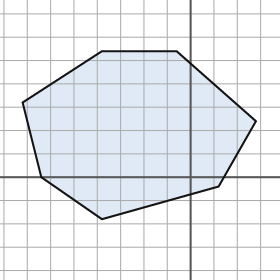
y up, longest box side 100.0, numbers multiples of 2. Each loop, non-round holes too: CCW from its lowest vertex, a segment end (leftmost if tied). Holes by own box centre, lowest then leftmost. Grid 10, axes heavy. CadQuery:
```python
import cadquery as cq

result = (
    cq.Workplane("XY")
    .moveTo(-38.0, -18.0)
    .lineTo(12.0, -4.0)
    .lineTo(28.0, 24.0)
    .lineTo(-6.0, 54.0)
    .lineTo(-38.0, 54.0)
    .lineTo(-72.0, 32.0)
    .lineTo(-64.0, 0.0)
    .close()
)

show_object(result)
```